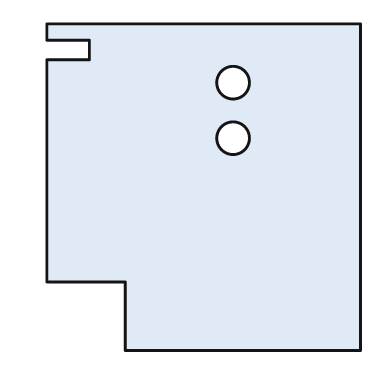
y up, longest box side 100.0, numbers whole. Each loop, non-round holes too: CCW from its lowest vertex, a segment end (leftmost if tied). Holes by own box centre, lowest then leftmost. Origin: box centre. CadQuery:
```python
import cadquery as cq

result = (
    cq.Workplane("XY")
    .moveTo(-24.0, -50.0)
    .lineTo(48.0, -50.0)
    .lineTo(48.0, 50.0)
    .lineTo(-48.0, 50.0)
    .lineTo(-48.0, 45.0)
    .lineTo(-35.0, 45.0)
    .lineTo(-35.0, 39.0)
    .lineTo(-48.0, 39.0)
    .lineTo(-48.0, -29.0)
    .lineTo(-24.0, -29.0)
    .close()
    .moveTo(9.0, 15.0)
    .circle(5.0)
    .moveTo(9.0, 32.0)
    .circle(5.0)
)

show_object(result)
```